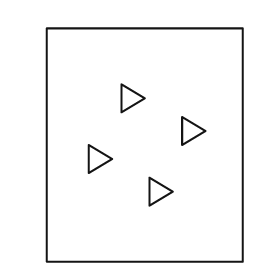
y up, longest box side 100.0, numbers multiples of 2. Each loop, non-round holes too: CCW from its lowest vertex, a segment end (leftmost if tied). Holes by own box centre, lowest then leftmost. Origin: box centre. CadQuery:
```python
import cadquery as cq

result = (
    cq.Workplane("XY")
    .moveTo(-42.0, -50.0)
    .lineTo(42.0, -50.0)
    .lineTo(42.0, 50.0)
    .lineTo(-42.0, 50.0)
    .close()
    .moveTo(2.0, -26.0)
    .lineTo(12.0, -20.0)
    .lineTo(2.0, -14.0)
    .close()
    .moveTo(-24.0, -12.0)
    .lineTo(-14.0, -6.0)
    .lineTo(-24.0, 0.0)
    .close()
    .moveTo(16.0, 0.0)
    .lineTo(26.0, 6.0)
    .lineTo(16.0, 12.0)
    .close()
    .moveTo(-10.0, 14.0)
    .lineTo(0.0, 20.0)
    .lineTo(-10.0, 26.0)
    .close()
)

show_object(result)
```